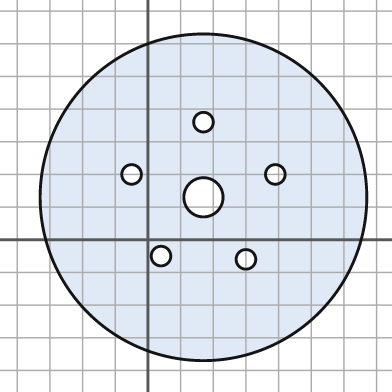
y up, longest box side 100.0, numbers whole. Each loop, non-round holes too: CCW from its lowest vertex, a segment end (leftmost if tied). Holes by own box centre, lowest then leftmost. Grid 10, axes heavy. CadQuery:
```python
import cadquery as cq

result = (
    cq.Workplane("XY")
    .moveTo(17.0, 13.0)
    .circle(50.0)
    .moveTo(30.0, -6.0)
    .circle(3.0)
    .moveTo(4.0, -5.0)
    .circle(3.0)
    .moveTo(17.0, 13.0)
    .circle(6.0)
    .moveTo(-5.0, 20.0)
    .circle(3.0)
    .moveTo(39.0, 20.0)
    .circle(3.0)
    .moveTo(17.0, 36.0)
    .circle(3.0)
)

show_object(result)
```